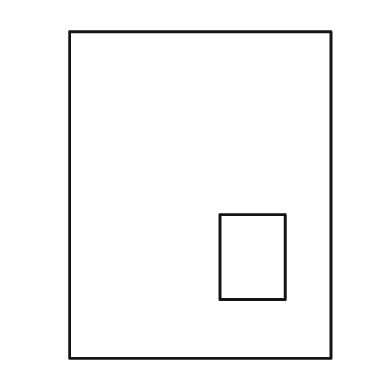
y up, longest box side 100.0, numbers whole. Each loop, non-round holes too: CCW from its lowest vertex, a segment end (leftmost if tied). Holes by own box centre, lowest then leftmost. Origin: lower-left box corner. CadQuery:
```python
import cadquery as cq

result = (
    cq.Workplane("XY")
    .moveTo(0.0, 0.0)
    .lineTo(80.0, 0.0)
    .lineTo(80.0, 100.0)
    .lineTo(0.0, 100.0)
    .close()
    .moveTo(46.0, 18.0)
    .lineTo(66.0, 18.0)
    .lineTo(66.0, 44.0)
    .lineTo(46.0, 44.0)
    .close()
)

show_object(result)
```